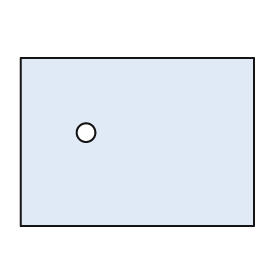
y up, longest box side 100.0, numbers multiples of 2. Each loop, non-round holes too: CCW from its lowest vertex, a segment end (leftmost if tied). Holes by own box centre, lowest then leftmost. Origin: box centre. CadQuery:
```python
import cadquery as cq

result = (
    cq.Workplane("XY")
    .moveTo(-50.0, -36.0)
    .lineTo(50.0, -36.0)
    .lineTo(50.0, 36.0)
    .lineTo(-50.0, 36.0)
    .close()
    .moveTo(-22.0, 4.0)
    .circle(4.0)
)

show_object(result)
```